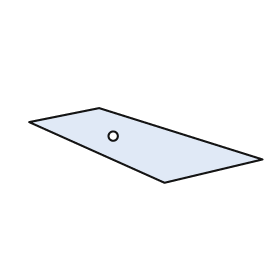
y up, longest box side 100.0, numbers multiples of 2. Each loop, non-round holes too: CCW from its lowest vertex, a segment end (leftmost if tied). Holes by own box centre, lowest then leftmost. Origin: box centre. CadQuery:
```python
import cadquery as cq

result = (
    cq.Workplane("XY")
    .moveTo(8.0, -16.0)
    .lineTo(50.0, -6.0)
    .lineTo(-20.0, 16.0)
    .lineTo(-50.0, 10.0)
    .close()
    .moveTo(-14.0, 4.0)
    .circle(2.0)
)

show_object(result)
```